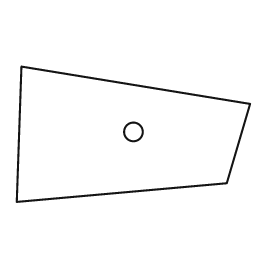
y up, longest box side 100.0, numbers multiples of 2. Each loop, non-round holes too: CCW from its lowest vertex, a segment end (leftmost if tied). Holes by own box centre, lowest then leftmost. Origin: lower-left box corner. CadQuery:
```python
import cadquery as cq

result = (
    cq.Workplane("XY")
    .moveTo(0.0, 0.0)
    .lineTo(90.0, 8.0)
    .lineTo(100.0, 42.0)
    .lineTo(2.0, 58.0)
    .close()
    .moveTo(50.0, 30.0)
    .circle(4.0)
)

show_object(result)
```